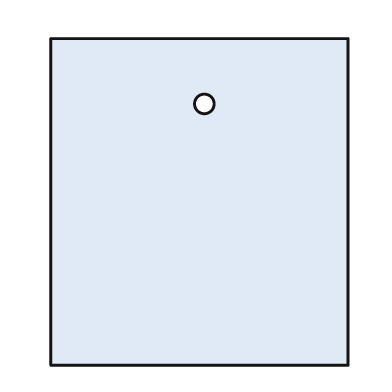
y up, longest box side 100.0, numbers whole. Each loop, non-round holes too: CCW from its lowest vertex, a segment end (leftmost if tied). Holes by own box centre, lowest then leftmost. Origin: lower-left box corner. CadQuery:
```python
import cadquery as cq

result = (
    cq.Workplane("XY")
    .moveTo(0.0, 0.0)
    .lineTo(91.0, 0.0)
    .lineTo(91.0, 100.0)
    .lineTo(0.0, 100.0)
    .close()
    .moveTo(47.0, 80.0)
    .circle(3.0)
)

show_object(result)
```